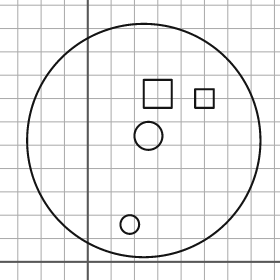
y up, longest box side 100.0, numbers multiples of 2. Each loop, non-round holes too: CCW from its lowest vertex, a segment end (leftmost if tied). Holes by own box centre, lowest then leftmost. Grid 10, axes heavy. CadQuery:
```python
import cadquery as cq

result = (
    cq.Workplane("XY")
    .moveTo(24.0, 52.0)
    .circle(50.0)
    .moveTo(18.0, 16.0)
    .circle(4.0)
    .moveTo(26.0, 54.0)
    .circle(6.0)
    .moveTo(46.0, 66.0)
    .lineTo(54.0, 66.0)
    .lineTo(54.0, 74.0)
    .lineTo(46.0, 74.0)
    .close()
    .moveTo(24.0, 66.0)
    .lineTo(36.0, 66.0)
    .lineTo(36.0, 78.0)
    .lineTo(24.0, 78.0)
    .close()
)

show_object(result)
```